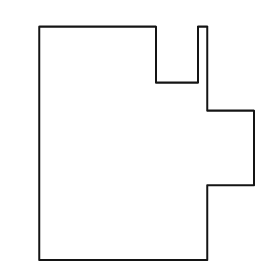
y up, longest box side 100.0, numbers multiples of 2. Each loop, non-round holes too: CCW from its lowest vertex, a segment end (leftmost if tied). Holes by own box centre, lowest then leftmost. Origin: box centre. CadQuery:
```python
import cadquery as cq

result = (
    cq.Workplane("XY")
    .moveTo(-46.0, -50.0)
    .lineTo(26.0, -50.0)
    .lineTo(26.0, -18.0)
    .lineTo(46.0, -18.0)
    .lineTo(46.0, 14.0)
    .lineTo(26.0, 14.0)
    .lineTo(26.0, 50.0)
    .lineTo(22.0, 50.0)
    .lineTo(22.0, 26.0)
    .lineTo(4.0, 26.0)
    .lineTo(4.0, 50.0)
    .lineTo(-46.0, 50.0)
    .close()
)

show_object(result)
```